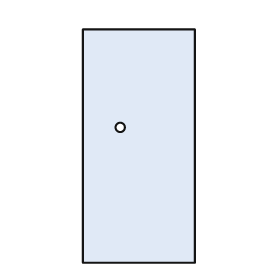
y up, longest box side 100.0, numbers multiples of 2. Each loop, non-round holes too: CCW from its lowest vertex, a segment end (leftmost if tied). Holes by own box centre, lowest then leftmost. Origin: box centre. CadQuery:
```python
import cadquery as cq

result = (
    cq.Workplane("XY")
    .moveTo(-24.0, -50.0)
    .lineTo(24.0, -50.0)
    .lineTo(24.0, 50.0)
    .lineTo(-24.0, 50.0)
    .close()
    .moveTo(-8.0, 8.0)
    .circle(2.0)
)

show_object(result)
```